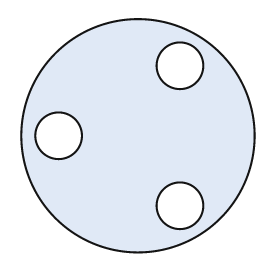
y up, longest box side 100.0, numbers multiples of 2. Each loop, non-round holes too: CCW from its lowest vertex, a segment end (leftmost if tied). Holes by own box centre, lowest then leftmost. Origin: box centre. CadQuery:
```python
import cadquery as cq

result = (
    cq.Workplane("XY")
    .moveTo(0.0, 0.0)
    .circle(50.0)
    .moveTo(18.0, -30.0)
    .circle(10.0)
    .moveTo(-34.0, 0.0)
    .circle(10.0)
    .moveTo(18.0, 30.0)
    .circle(10.0)
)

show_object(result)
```